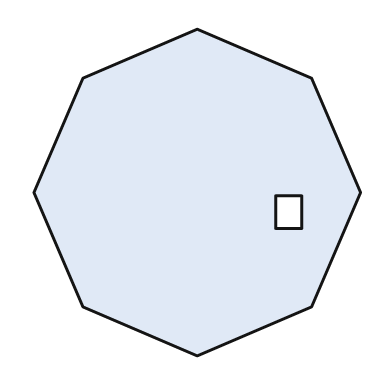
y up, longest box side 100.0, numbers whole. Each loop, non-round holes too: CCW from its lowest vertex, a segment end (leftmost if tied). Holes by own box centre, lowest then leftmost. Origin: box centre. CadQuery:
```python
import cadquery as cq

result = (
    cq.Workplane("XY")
    .moveTo(0.0, -50.0)
    .lineTo(35.0, -35.0)
    .lineTo(50.0, 0.0)
    .lineTo(35.0, 35.0)
    .lineTo(0.0, 50.0)
    .lineTo(-35.0, 35.0)
    .lineTo(-50.0, 0.0)
    .lineTo(-35.0, -35.0)
    .close()
    .moveTo(24.0, -11.0)
    .lineTo(32.0, -11.0)
    .lineTo(32.0, -1.0)
    .lineTo(24.0, -1.0)
    .close()
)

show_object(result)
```